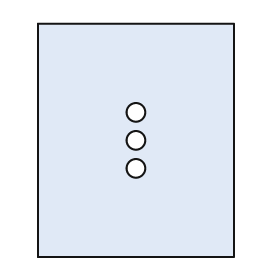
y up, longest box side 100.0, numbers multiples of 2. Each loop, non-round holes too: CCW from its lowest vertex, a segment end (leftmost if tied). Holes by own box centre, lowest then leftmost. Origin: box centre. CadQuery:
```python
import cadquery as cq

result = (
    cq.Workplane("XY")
    .moveTo(-42.0, -50.0)
    .lineTo(42.0, -50.0)
    .lineTo(42.0, 50.0)
    .lineTo(-42.0, 50.0)
    .close()
    .moveTo(0.0, -12.0)
    .circle(4.0)
    .moveTo(0.0, 0.0)
    .circle(4.0)
    .moveTo(0.0, 12.0)
    .circle(4.0)
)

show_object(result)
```